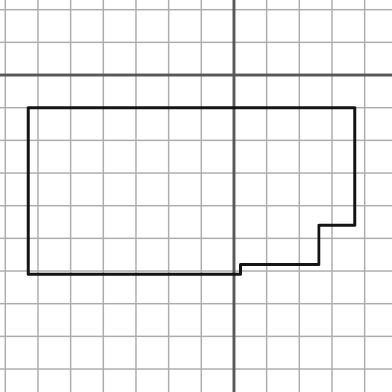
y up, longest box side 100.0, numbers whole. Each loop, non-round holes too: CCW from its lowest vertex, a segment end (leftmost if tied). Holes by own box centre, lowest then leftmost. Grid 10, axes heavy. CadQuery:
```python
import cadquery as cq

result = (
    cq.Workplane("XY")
    .moveTo(-63.0, -61.0)
    .lineTo(2.0, -61.0)
    .lineTo(2.0, -58.0)
    .lineTo(26.0, -58.0)
    .lineTo(26.0, -46.0)
    .lineTo(37.0, -46.0)
    .lineTo(37.0, -10.0)
    .lineTo(-63.0, -10.0)
    .close()
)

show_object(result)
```